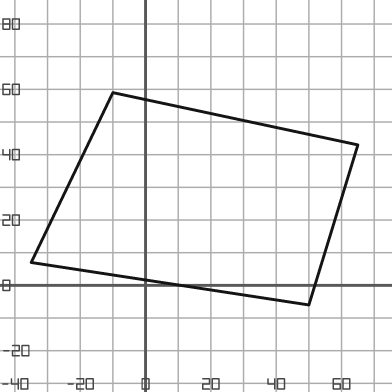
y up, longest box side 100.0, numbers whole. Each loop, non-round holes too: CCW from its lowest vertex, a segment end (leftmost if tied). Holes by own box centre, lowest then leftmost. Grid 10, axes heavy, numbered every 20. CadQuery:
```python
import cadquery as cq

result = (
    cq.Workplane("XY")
    .moveTo(50.0, -6.0)
    .lineTo(65.0, 43.0)
    .lineTo(-10.0, 59.0)
    .lineTo(-35.0, 7.0)
    .close()
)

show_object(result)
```